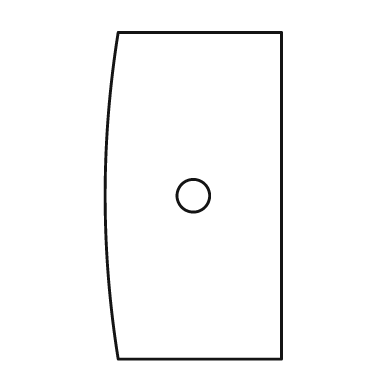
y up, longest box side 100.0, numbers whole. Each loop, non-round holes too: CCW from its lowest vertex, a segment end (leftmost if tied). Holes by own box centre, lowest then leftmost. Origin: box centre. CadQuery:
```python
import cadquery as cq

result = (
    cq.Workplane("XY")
    .moveTo(-23.0, -50.0)
    .lineTo(27.0, -50.0)
    .lineTo(27.0, 50.0)
    .lineTo(-23.0, 50.0)
    .threePointArc((-27.0, 0.0), (-23.0, -50.0))
    .close()
    .moveTo(0.0, 0.0)
    .circle(5.0)
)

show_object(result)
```